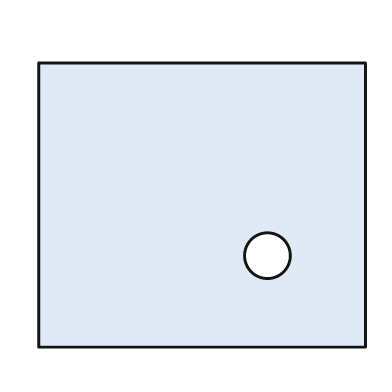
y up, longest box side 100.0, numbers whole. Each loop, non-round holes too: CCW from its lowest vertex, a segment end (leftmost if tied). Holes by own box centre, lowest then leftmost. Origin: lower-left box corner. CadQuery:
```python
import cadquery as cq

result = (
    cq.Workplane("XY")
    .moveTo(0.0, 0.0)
    .lineTo(100.0, 0.0)
    .lineTo(100.0, 87.0)
    .lineTo(0.0, 87.0)
    .close()
    .moveTo(70.0, 28.0)
    .circle(7.0)
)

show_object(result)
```